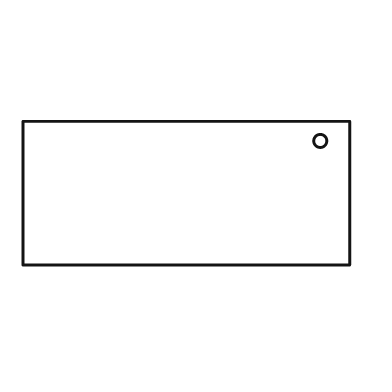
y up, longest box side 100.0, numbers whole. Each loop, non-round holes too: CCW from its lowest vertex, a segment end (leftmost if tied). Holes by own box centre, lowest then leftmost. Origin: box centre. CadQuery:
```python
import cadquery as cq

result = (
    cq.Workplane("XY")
    .moveTo(-50.0, -22.0)
    .lineTo(50.0, -22.0)
    .lineTo(50.0, 22.0)
    .lineTo(-50.0, 22.0)
    .close()
    .moveTo(41.0, 16.0)
    .circle(2.0)
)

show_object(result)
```